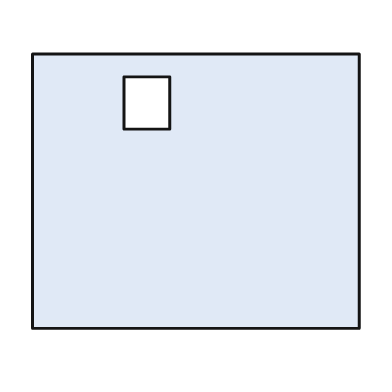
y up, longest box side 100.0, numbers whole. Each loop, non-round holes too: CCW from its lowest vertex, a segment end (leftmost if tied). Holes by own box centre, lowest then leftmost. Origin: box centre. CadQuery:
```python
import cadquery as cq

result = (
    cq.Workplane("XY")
    .moveTo(-50.0, -42.0)
    .lineTo(50.0, -42.0)
    .lineTo(50.0, 42.0)
    .lineTo(-50.0, 42.0)
    .close()
    .moveTo(-22.0, 19.0)
    .lineTo(-8.0, 19.0)
    .lineTo(-8.0, 35.0)
    .lineTo(-22.0, 35.0)
    .close()
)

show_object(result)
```